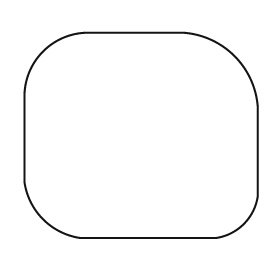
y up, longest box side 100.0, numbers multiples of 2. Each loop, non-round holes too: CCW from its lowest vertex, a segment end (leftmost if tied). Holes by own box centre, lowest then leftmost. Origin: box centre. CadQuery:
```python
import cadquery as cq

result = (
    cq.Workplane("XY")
    .moveTo(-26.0, -44.0)
    .lineTo(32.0, -44.0)
    .threePointArc((44.0, -38.0), (50.0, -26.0))
    .lineTo(50.0, 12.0)
    .threePointArc((40.0, 34.0), (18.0, 44.0))
    .lineTo(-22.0, 44.0)
    .threePointArc((-42.0, 36.0), (-50.0, 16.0))
    .lineTo(-50.0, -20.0)
    .threePointArc((-42.0, -36.0), (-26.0, -44.0))
    .close()
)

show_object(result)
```